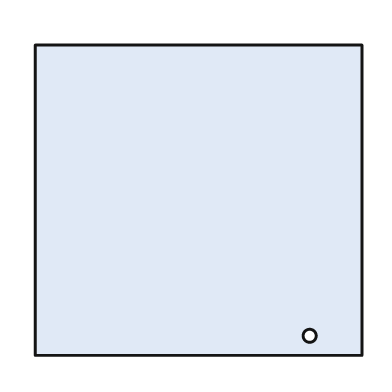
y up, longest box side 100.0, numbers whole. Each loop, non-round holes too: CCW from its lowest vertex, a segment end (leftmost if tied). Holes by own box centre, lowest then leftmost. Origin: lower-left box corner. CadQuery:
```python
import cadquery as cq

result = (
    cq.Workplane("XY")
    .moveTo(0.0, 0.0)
    .lineTo(100.0, 0.0)
    .lineTo(100.0, 95.0)
    .lineTo(0.0, 95.0)
    .close()
    .moveTo(84.0, 6.0)
    .circle(2.0)
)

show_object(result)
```